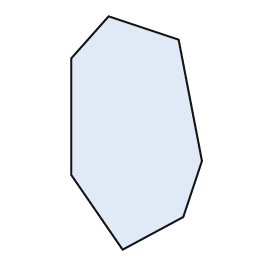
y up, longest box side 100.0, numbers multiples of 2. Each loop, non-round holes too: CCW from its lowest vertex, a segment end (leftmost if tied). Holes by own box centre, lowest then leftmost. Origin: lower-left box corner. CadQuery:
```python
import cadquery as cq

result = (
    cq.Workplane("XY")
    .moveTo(22.0, 0.0)
    .lineTo(48.0, 14.0)
    .lineTo(56.0, 38.0)
    .lineTo(46.0, 90.0)
    .lineTo(16.0, 100.0)
    .lineTo(0.0, 82.0)
    .lineTo(0.0, 32.0)
    .close()
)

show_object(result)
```